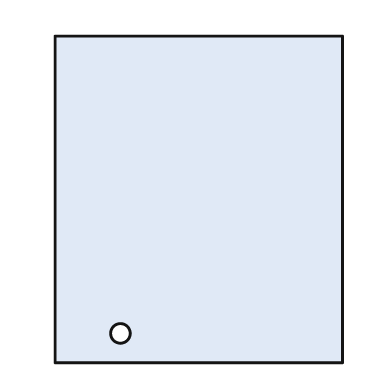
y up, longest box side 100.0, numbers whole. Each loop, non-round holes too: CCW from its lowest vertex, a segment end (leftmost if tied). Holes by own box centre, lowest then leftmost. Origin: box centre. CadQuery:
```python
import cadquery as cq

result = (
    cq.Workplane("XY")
    .moveTo(-44.0, -50.0)
    .lineTo(44.0, -50.0)
    .lineTo(44.0, 50.0)
    .lineTo(-44.0, 50.0)
    .close()
    .moveTo(-24.0, -41.0)
    .circle(3.0)
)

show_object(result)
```